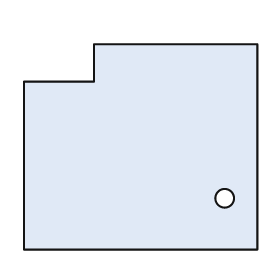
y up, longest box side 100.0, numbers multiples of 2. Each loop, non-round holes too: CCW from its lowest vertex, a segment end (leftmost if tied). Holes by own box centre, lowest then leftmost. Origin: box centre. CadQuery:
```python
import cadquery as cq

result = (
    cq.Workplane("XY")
    .moveTo(-50.0, -44.0)
    .lineTo(50.0, -44.0)
    .lineTo(50.0, 44.0)
    .lineTo(-20.0, 44.0)
    .lineTo(-20.0, 28.0)
    .lineTo(-50.0, 28.0)
    .close()
    .moveTo(36.0, -22.0)
    .circle(4.0)
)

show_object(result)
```